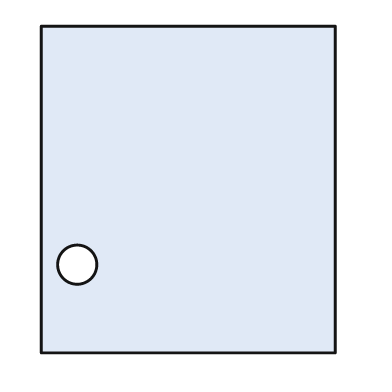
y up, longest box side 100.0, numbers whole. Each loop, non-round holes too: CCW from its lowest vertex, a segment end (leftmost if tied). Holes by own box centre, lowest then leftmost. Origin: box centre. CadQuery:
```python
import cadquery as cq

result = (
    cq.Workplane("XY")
    .moveTo(-45.0, -50.0)
    .lineTo(45.0, -50.0)
    .lineTo(45.0, 50.0)
    .lineTo(-45.0, 50.0)
    .close()
    .moveTo(-34.0, -23.0)
    .circle(6.0)
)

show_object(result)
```